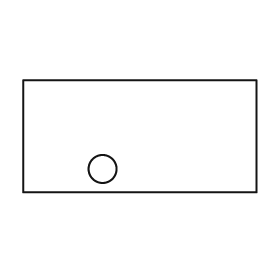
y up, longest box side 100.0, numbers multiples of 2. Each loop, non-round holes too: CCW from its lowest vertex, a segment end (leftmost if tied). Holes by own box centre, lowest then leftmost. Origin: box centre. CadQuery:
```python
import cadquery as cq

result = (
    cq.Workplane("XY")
    .moveTo(-50.0, -24.0)
    .lineTo(50.0, -24.0)
    .lineTo(50.0, 24.0)
    .lineTo(-50.0, 24.0)
    .close()
    .moveTo(-16.0, -14.0)
    .circle(6.0)
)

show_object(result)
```